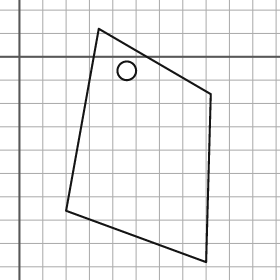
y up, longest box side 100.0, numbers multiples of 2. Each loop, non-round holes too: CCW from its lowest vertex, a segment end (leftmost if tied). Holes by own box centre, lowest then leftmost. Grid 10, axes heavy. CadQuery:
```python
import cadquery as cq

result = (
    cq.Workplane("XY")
    .moveTo(80.0, -88.0)
    .lineTo(82.0, -16.0)
    .lineTo(34.0, 12.0)
    .lineTo(20.0, -66.0)
    .close()
    .moveTo(46.0, -6.0)
    .circle(4.0)
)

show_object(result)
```